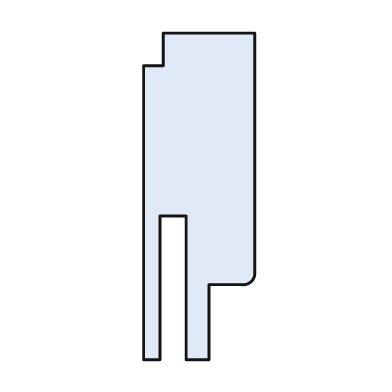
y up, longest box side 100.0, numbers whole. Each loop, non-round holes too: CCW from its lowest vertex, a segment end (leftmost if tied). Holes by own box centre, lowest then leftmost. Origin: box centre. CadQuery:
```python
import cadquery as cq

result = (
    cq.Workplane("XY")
    .moveTo(-17.0, -50.0)
    .lineTo(-12.0, -50.0)
    .lineTo(-12.0, -6.0)
    .lineTo(-4.0, -6.0)
    .lineTo(-4.0, -50.0)
    .lineTo(3.0, -50.0)
    .lineTo(3.0, -27.0)
    .lineTo(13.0, -27.0)
    .threePointArc((16.0, -26.0), (17.0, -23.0))
    .lineTo(17.0, 50.0)
    .lineTo(-11.0, 50.0)
    .lineTo(-11.0, 40.0)
    .lineTo(-17.0, 40.0)
    .close()
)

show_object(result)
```